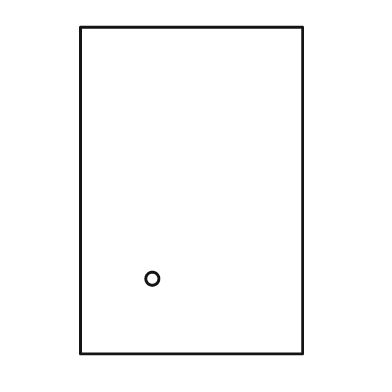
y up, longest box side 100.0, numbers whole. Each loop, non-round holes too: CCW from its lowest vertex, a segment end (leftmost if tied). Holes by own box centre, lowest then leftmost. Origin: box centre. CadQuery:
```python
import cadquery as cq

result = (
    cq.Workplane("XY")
    .moveTo(-34.0, -50.0)
    .lineTo(34.0, -50.0)
    .lineTo(34.0, 50.0)
    .lineTo(-34.0, 50.0)
    .close()
    .moveTo(-12.0, -27.0)
    .circle(2.0)
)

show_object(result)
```